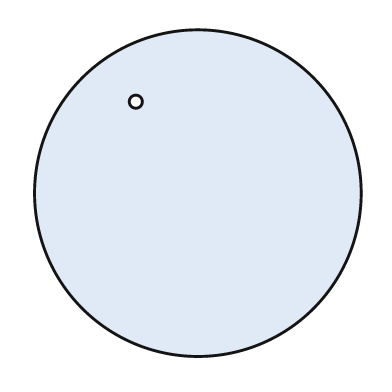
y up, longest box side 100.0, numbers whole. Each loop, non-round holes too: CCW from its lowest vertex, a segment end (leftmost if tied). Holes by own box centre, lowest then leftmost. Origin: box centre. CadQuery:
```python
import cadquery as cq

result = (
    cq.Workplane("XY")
    .moveTo(0.0, 0.0)
    .circle(50.0)
    .moveTo(-19.0, 28.0)
    .circle(2.0)
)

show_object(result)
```